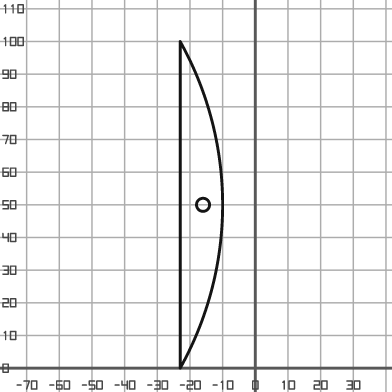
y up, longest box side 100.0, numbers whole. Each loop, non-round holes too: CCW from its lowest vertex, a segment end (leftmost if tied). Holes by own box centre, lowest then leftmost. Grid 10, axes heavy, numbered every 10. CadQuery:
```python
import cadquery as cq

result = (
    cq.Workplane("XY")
    .moveTo(-23.0, 0.0)
    .threePointArc((-10.0, 50.0), (-23.0, 100.0))
    .close()
    .moveTo(-16.0, 50.0)
    .circle(2.0)
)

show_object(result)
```